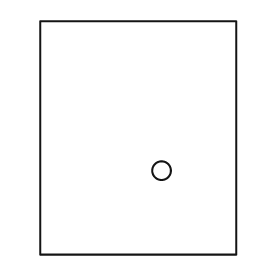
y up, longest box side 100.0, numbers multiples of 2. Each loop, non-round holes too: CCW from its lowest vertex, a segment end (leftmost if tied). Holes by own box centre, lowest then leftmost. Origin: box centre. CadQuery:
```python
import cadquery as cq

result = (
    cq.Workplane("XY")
    .moveTo(-42.0, -50.0)
    .lineTo(42.0, -50.0)
    .lineTo(42.0, 50.0)
    .lineTo(-42.0, 50.0)
    .close()
    .moveTo(10.0, -14.0)
    .circle(4.0)
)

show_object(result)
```